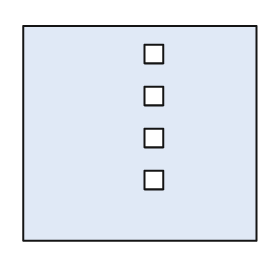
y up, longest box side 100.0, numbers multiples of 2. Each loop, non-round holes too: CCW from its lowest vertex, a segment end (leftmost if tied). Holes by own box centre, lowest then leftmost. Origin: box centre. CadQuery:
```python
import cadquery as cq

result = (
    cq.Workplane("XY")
    .moveTo(-50.0, -46.0)
    .lineTo(50.0, -46.0)
    .lineTo(50.0, 46.0)
    .lineTo(-50.0, 46.0)
    .close()
    .moveTo(2.0, -24.0)
    .lineTo(10.0, -24.0)
    .lineTo(10.0, -16.0)
    .lineTo(2.0, -16.0)
    .close()
    .moveTo(2.0, -6.0)
    .lineTo(10.0, -6.0)
    .lineTo(10.0, 2.0)
    .lineTo(2.0, 2.0)
    .close()
    .moveTo(2.0, 12.0)
    .lineTo(10.0, 12.0)
    .lineTo(10.0, 20.0)
    .lineTo(2.0, 20.0)
    .close()
    .moveTo(2.0, 30.0)
    .lineTo(10.0, 30.0)
    .lineTo(10.0, 38.0)
    .lineTo(2.0, 38.0)
    .close()
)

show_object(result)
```